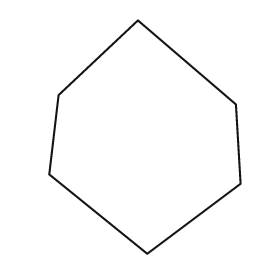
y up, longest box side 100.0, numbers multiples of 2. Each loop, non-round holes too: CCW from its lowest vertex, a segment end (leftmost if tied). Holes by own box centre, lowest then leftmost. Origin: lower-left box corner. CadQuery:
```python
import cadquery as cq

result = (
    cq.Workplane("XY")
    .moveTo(42.0, 0.0)
    .lineTo(82.0, 30.0)
    .lineTo(80.0, 64.0)
    .lineTo(38.0, 100.0)
    .lineTo(4.0, 68.0)
    .lineTo(0.0, 34.0)
    .close()
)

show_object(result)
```